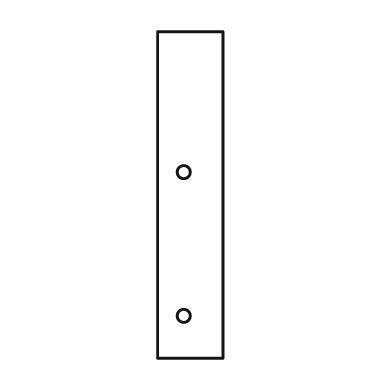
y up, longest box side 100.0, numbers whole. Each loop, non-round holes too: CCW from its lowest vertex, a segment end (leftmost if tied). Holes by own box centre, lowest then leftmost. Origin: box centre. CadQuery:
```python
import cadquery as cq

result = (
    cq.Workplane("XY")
    .moveTo(-10.0, -50.0)
    .lineTo(10.0, -50.0)
    .lineTo(10.0, 50.0)
    .lineTo(-10.0, 50.0)
    .close()
    .moveTo(-2.0, -37.0)
    .circle(2.0)
    .moveTo(-2.0, 7.0)
    .circle(2.0)
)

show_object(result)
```